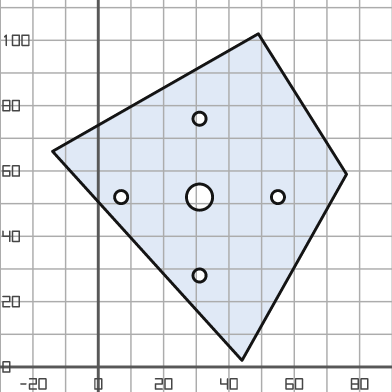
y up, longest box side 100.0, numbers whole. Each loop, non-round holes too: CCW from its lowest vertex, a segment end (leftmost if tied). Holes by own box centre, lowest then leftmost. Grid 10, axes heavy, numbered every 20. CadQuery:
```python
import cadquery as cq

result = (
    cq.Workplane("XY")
    .moveTo(44.0, 2.0)
    .lineTo(76.0, 59.0)
    .lineTo(49.0, 102.0)
    .lineTo(-14.0, 66.0)
    .close()
    .moveTo(31.0, 28.0)
    .circle(2.0)
    .moveTo(7.0, 52.0)
    .circle(2.0)
    .moveTo(31.0, 52.0)
    .circle(4.0)
    .moveTo(55.0, 52.0)
    .circle(2.0)
    .moveTo(31.0, 76.0)
    .circle(2.0)
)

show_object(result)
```